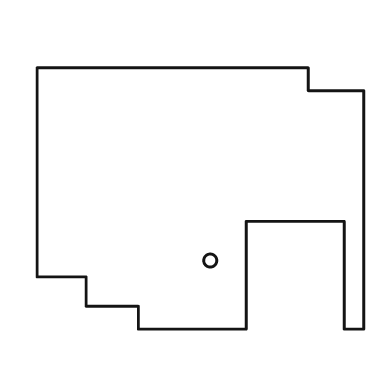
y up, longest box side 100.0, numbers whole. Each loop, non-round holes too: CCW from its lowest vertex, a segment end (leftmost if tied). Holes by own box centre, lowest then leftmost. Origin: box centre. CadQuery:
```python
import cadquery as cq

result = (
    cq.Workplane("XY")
    .moveTo(-19.0, -40.0)
    .lineTo(14.0, -40.0)
    .lineTo(14.0, -7.0)
    .lineTo(44.0, -7.0)
    .lineTo(44.0, -40.0)
    .lineTo(50.0, -40.0)
    .lineTo(50.0, 33.0)
    .lineTo(33.0, 33.0)
    .lineTo(33.0, 40.0)
    .lineTo(-50.0, 40.0)
    .lineTo(-50.0, -24.0)
    .lineTo(-35.0, -24.0)
    .lineTo(-35.0, -33.0)
    .lineTo(-19.0, -33.0)
    .close()
    .moveTo(3.0, -19.0)
    .circle(2.0)
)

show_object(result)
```